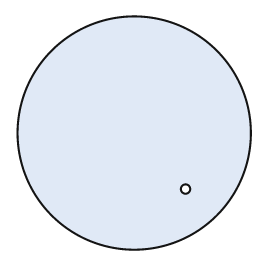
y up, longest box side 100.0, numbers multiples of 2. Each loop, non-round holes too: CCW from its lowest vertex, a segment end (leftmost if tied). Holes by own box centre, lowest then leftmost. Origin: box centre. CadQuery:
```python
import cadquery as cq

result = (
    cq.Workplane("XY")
    .moveTo(0.0, 0.0)
    .circle(50.0)
    .moveTo(22.0, -24.0)
    .circle(2.0)
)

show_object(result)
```